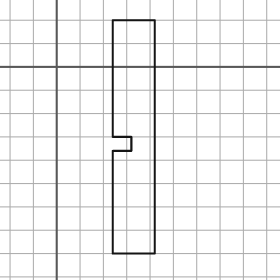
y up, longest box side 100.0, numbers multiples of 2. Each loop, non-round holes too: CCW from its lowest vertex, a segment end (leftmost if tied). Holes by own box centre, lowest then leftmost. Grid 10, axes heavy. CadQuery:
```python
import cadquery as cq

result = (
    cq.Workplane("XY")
    .moveTo(24.0, -80.0)
    .lineTo(42.0, -80.0)
    .lineTo(42.0, 20.0)
    .lineTo(24.0, 20.0)
    .lineTo(24.0, -30.0)
    .lineTo(32.0, -30.0)
    .lineTo(32.0, -36.0)
    .lineTo(24.0, -36.0)
    .close()
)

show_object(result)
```